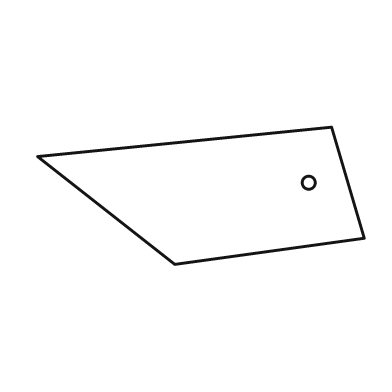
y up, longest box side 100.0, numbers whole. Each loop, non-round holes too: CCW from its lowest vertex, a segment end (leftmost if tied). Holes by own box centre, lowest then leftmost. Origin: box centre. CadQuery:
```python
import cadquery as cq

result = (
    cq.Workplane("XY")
    .moveTo(-8.0, -21.0)
    .lineTo(50.0, -13.0)
    .lineTo(40.0, 21.0)
    .lineTo(-50.0, 12.0)
    .close()
    .moveTo(33.0, 4.0)
    .circle(2.0)
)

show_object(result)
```